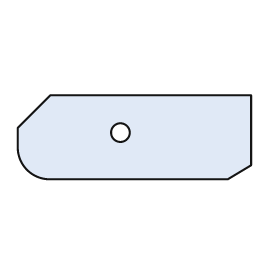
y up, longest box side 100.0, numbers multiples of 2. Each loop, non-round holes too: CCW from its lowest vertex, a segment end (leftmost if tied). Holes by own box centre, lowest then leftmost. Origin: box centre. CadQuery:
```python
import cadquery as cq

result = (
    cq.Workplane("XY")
    .moveTo(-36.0, -18.0)
    .lineTo(40.0, -18.0)
    .lineTo(50.0, -12.0)
    .lineTo(50.0, 18.0)
    .lineTo(-36.0, 18.0)
    .lineTo(-50.0, 4.0)
    .lineTo(-50.0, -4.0)
    .threePointArc((-46.0, -14.0), (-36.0, -18.0))
    .close()
    .moveTo(-6.0, 2.0)
    .circle(4.0)
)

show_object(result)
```